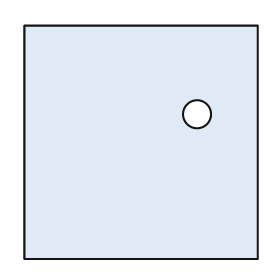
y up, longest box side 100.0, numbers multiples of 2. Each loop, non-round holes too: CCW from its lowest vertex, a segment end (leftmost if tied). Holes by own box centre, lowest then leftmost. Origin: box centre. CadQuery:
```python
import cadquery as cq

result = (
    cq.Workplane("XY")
    .moveTo(-50.0, -50.0)
    .lineTo(50.0, -50.0)
    .lineTo(50.0, 50.0)
    .lineTo(-50.0, 50.0)
    .close()
    .moveTo(24.0, 12.0)
    .circle(6.0)
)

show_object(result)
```